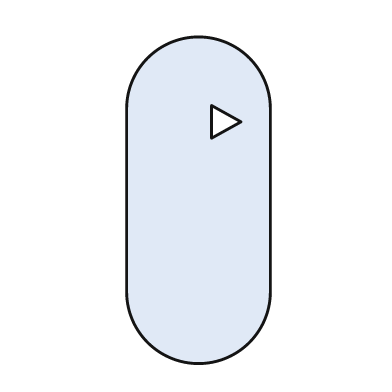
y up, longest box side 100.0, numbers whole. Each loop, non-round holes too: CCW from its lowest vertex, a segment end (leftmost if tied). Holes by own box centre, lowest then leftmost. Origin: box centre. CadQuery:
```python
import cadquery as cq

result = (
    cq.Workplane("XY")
    .moveTo(-22.0, -28.0)
    .threePointArc((0.0, -50.0), (22.0, -28.0))
    .lineTo(22.0, 28.0)
    .threePointArc((0.0, 50.0), (-22.0, 28.0))
    .close()
    .moveTo(4.0, 19.0)
    .lineTo(13.0, 24.0)
    .lineTo(4.0, 29.0)
    .close()
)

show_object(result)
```